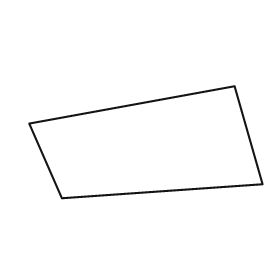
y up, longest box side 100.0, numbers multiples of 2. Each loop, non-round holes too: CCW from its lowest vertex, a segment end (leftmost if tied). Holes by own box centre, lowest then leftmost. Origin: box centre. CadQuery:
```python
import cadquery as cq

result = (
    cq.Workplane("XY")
    .moveTo(-36.0, -24.0)
    .lineTo(50.0, -18.0)
    .lineTo(38.0, 24.0)
    .lineTo(-50.0, 8.0)
    .close()
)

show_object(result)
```